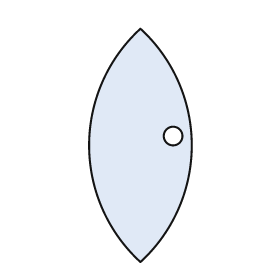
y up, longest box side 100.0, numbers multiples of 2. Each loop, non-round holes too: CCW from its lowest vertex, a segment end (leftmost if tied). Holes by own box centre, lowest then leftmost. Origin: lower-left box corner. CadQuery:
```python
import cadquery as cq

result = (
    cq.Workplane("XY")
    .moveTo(22.0, 0.0)
    .threePointArc((44.0, 50.0), (22.0, 100.0))
    .threePointArc((0.0, 50.0), (22.0, 0.0))
    .close()
    .moveTo(36.0, 54.0)
    .circle(4.0)
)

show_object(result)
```